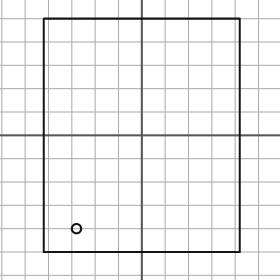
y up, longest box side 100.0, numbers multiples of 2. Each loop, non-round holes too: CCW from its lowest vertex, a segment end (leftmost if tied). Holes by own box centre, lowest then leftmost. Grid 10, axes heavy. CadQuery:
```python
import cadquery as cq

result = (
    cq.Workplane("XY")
    .moveTo(-42.0, -50.0)
    .lineTo(42.0, -50.0)
    .lineTo(42.0, 50.0)
    .lineTo(-42.0, 50.0)
    .close()
    .moveTo(-28.0, -40.0)
    .circle(2.0)
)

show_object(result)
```